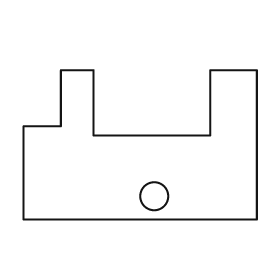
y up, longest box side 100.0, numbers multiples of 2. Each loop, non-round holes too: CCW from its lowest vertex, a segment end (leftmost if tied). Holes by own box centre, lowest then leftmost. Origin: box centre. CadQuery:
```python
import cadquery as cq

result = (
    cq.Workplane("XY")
    .moveTo(-50.0, -32.0)
    .lineTo(50.0, -32.0)
    .lineTo(50.0, 32.0)
    .lineTo(30.0, 32.0)
    .lineTo(30.0, 4.0)
    .lineTo(-20.0, 4.0)
    .lineTo(-20.0, 32.0)
    .lineTo(-34.0, 32.0)
    .lineTo(-34.0, 8.0)
    .lineTo(-50.0, 8.0)
    .close()
    .moveTo(6.0, -22.0)
    .circle(6.0)
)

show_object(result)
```